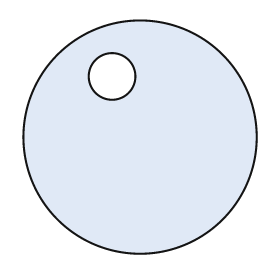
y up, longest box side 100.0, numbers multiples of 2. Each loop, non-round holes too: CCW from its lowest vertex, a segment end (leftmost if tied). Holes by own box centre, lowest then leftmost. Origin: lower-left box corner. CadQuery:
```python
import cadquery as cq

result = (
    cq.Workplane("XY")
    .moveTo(50.0, 50.0)
    .circle(50.0)
    .moveTo(38.0, 76.0)
    .circle(10.0)
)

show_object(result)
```